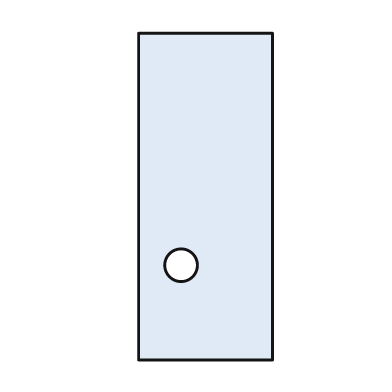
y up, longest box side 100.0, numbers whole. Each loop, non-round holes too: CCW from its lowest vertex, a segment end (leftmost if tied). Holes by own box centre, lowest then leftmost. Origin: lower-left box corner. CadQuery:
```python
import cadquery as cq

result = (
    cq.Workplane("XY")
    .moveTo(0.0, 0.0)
    .lineTo(41.0, 0.0)
    .lineTo(41.0, 100.0)
    .lineTo(0.0, 100.0)
    .close()
    .moveTo(13.0, 29.0)
    .circle(5.0)
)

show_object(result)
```